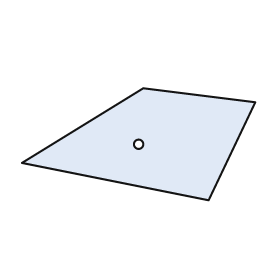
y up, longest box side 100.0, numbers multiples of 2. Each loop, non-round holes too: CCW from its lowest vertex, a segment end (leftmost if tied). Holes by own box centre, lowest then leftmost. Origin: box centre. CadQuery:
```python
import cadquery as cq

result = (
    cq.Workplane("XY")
    .moveTo(30.0, -24.0)
    .lineTo(50.0, 18.0)
    .lineTo(2.0, 24.0)
    .lineTo(-50.0, -8.0)
    .close()
    .moveTo(0.0, 0.0)
    .circle(2.0)
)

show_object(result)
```